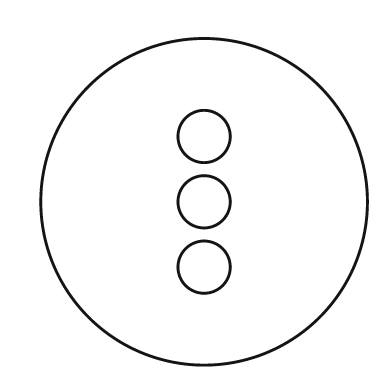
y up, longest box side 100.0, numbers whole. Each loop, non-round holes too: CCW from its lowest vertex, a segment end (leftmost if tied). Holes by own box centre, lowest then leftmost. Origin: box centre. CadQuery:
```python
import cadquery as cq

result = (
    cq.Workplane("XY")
    .moveTo(0.0, 0.0)
    .circle(50.0)
    .moveTo(0.0, -20.0)
    .circle(8.0)
    .moveTo(0.0, 0.0)
    .circle(8.0)
    .moveTo(0.0, 20.0)
    .circle(8.0)
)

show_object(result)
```